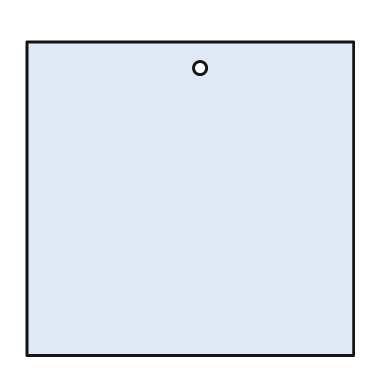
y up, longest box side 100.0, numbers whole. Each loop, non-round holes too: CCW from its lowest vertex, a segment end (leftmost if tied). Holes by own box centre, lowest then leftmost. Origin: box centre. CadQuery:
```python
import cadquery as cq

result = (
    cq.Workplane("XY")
    .moveTo(-50.0, -48.0)
    .lineTo(50.0, -48.0)
    .lineTo(50.0, 48.0)
    .lineTo(-50.0, 48.0)
    .close()
    .moveTo(3.0, 40.0)
    .circle(2.0)
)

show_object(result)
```